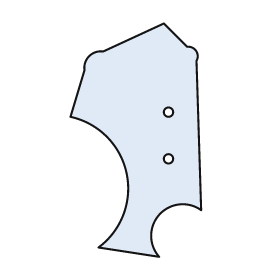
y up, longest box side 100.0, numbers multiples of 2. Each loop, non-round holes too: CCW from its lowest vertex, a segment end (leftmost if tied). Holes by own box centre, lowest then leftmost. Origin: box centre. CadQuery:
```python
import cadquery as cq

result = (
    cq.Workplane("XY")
    .moveTo(10.0, -50.0)
    .threePointArc((10.0, -32.0), (28.0, -30.0))
    .lineTo(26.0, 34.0)
    .threePointArc((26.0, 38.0), (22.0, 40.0))
    .lineTo(12.0, 50.0)
    .lineTo(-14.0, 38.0)
    .threePointArc((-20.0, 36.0), (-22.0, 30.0))
    .lineTo(-28.0, 10.0)
    .threePointArc((-4.0, -14.0), (-16.0, -46.0))
    .close()
    .moveTo(14.0, -8.0)
    .circle(2.0)
    .moveTo(14.0, 12.0)
    .circle(2.0)
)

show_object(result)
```